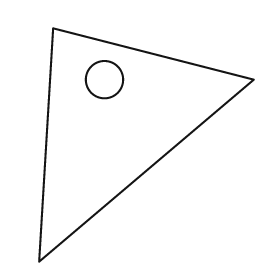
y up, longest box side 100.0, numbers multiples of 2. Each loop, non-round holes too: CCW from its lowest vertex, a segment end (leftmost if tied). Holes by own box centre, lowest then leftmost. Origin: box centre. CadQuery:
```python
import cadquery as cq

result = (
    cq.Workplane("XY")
    .moveTo(-46.0, -50.0)
    .lineTo(46.0, 28.0)
    .lineTo(-40.0, 50.0)
    .close()
    .moveTo(-18.0, 28.0)
    .circle(8.0)
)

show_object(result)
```